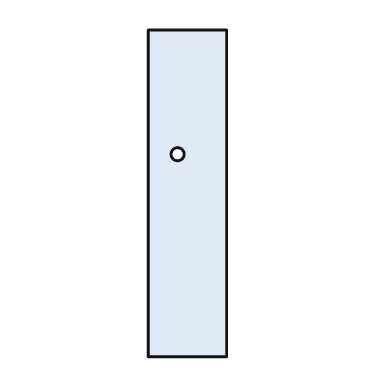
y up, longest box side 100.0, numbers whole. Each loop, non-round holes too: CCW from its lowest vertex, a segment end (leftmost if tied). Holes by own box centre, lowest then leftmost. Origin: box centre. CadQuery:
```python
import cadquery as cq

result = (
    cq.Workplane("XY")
    .moveTo(-12.0, -50.0)
    .lineTo(12.0, -50.0)
    .lineTo(12.0, 50.0)
    .lineTo(-12.0, 50.0)
    .close()
    .moveTo(-3.0, 12.0)
    .circle(2.0)
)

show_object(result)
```